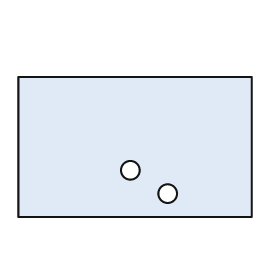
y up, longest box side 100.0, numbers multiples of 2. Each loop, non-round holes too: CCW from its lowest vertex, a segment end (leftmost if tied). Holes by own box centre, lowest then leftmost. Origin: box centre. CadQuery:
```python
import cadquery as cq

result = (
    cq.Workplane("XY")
    .moveTo(-50.0, -30.0)
    .lineTo(50.0, -30.0)
    .lineTo(50.0, 30.0)
    .lineTo(-50.0, 30.0)
    .close()
    .moveTo(14.0, -20.0)
    .circle(4.0)
    .moveTo(-2.0, -10.0)
    .circle(4.0)
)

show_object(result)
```